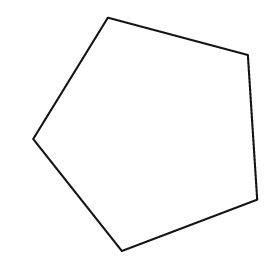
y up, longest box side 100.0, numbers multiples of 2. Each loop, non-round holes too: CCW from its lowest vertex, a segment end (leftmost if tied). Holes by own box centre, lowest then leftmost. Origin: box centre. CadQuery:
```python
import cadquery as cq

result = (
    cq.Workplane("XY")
    .moveTo(-10.0, -50.0)
    .lineTo(48.0, -28.0)
    .lineTo(44.0, 34.0)
    .lineTo(-16.0, 50.0)
    .lineTo(-48.0, -2.0)
    .close()
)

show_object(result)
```